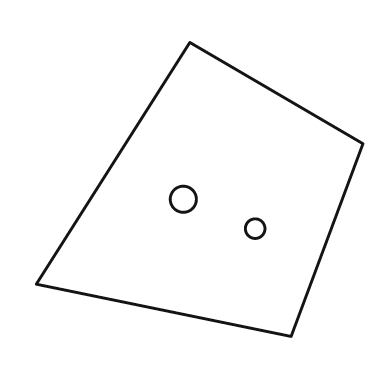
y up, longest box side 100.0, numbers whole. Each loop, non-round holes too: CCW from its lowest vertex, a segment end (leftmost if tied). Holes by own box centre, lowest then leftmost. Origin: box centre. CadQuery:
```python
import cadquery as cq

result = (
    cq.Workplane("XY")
    .moveTo(28.0, -45.0)
    .lineTo(50.0, 14.0)
    .lineTo(-3.0, 45.0)
    .lineTo(-50.0, -29.0)
    .close()
    .moveTo(17.0, -12.0)
    .circle(3.0)
    .moveTo(-5.0, -3.0)
    .circle(4.0)
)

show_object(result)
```